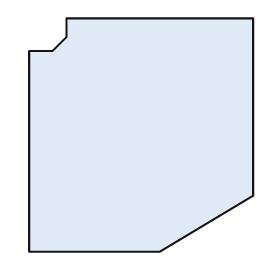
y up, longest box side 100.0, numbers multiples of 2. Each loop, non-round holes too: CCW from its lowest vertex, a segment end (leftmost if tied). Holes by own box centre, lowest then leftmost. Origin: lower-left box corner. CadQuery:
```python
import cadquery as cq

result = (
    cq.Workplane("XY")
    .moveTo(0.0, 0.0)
    .lineTo(56.0, 0.0)
    .lineTo(96.0, 24.0)
    .lineTo(96.0, 100.0)
    .lineTo(16.0, 100.0)
    .lineTo(16.0, 92.0)
    .lineTo(10.0, 86.0)
    .lineTo(0.0, 86.0)
    .close()
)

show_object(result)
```